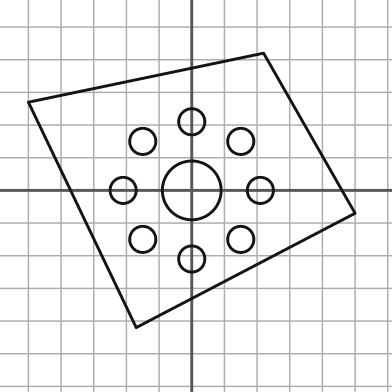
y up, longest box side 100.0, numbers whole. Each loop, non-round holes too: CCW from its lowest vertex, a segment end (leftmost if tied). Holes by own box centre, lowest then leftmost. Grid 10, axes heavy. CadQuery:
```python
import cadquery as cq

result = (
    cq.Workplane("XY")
    .moveTo(-17.0, -42.0)
    .lineTo(50.0, -7.0)
    .lineTo(22.0, 42.0)
    .lineTo(-50.0, 27.0)
    .close()
    .moveTo(0.0, -21.0)
    .circle(4.0)
    .moveTo(-15.0, -15.0)
    .circle(4.0)
    .moveTo(15.0, -15.0)
    .circle(4.0)
    .moveTo(-21.0, 0.0)
    .circle(4.0)
    .moveTo(0.0, 0.0)
    .circle(9.0)
    .moveTo(21.0, 0.0)
    .circle(4.0)
    .moveTo(-15.0, 15.0)
    .circle(4.0)
    .moveTo(15.0, 15.0)
    .circle(4.0)
    .moveTo(0.0, 21.0)
    .circle(4.0)
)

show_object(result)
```